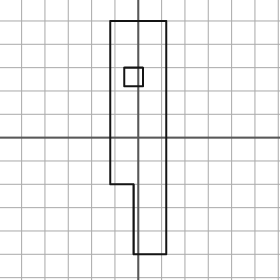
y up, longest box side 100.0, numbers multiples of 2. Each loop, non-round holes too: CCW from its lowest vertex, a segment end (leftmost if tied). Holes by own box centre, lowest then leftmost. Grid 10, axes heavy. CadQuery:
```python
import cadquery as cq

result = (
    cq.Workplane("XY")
    .moveTo(-2.0, -50.0)
    .lineTo(12.0, -50.0)
    .lineTo(12.0, 50.0)
    .lineTo(-12.0, 50.0)
    .lineTo(-12.0, -20.0)
    .lineTo(-2.0, -20.0)
    .close()
    .moveTo(-6.0, 22.0)
    .lineTo(2.0, 22.0)
    .lineTo(2.0, 30.0)
    .lineTo(-6.0, 30.0)
    .close()
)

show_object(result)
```